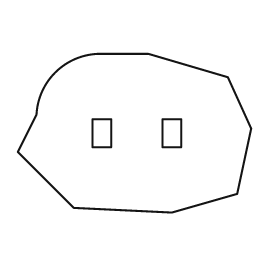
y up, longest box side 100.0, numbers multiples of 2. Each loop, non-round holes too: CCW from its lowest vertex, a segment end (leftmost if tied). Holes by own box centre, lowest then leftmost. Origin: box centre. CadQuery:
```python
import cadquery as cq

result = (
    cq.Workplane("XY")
    .moveTo(16.0, -34.0)
    .lineTo(44.0, -26.0)
    .lineTo(50.0, 2.0)
    .lineTo(40.0, 24.0)
    .lineTo(6.0, 34.0)
    .lineTo(-16.0, 34.0)
    .threePointArc((-34.0, 26.0), (-42.0, 8.0))
    .lineTo(-50.0, -8.0)
    .lineTo(-26.0, -32.0)
    .close()
    .moveTo(-18.0, -6.0)
    .lineTo(-10.0, -6.0)
    .lineTo(-10.0, 6.0)
    .lineTo(-18.0, 6.0)
    .close()
    .moveTo(12.0, -6.0)
    .lineTo(20.0, -6.0)
    .lineTo(20.0, 6.0)
    .lineTo(12.0, 6.0)
    .close()
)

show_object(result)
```